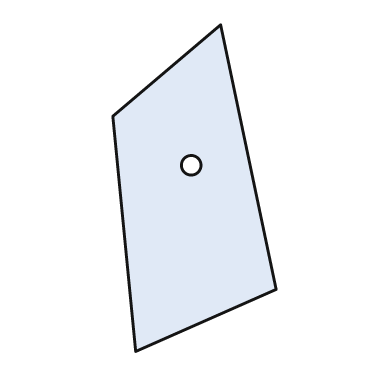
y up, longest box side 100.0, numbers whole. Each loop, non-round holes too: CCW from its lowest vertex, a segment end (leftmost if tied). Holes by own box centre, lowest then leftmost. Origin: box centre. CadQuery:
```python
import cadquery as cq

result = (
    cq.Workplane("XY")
    .moveTo(-18.0, -50.0)
    .lineTo(25.0, -31.0)
    .lineTo(8.0, 50.0)
    .lineTo(-25.0, 22.0)
    .close()
    .moveTo(-1.0, 7.0)
    .circle(3.0)
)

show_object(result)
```